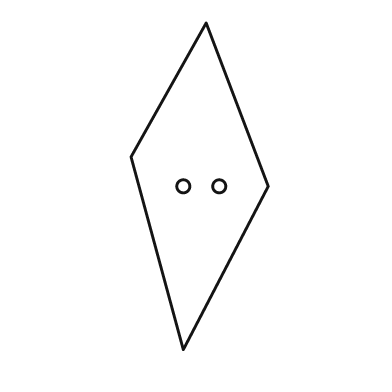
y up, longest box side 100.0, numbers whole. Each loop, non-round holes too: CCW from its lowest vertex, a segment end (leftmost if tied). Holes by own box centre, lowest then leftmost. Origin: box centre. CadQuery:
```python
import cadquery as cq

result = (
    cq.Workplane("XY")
    .moveTo(-5.0, -50.0)
    .lineTo(21.0, 0.0)
    .lineTo(2.0, 50.0)
    .lineTo(-21.0, 9.0)
    .close()
    .moveTo(-5.0, 0.0)
    .circle(2.0)
    .moveTo(6.0, 0.0)
    .circle(2.0)
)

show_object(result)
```